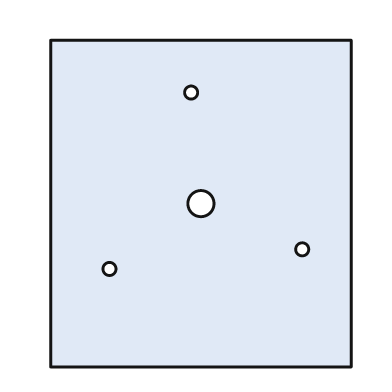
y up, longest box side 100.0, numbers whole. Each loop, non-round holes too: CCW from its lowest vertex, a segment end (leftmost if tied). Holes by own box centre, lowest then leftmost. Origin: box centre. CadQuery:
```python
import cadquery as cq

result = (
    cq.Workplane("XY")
    .moveTo(-46.0, -50.0)
    .lineTo(46.0, -50.0)
    .lineTo(46.0, 50.0)
    .lineTo(-46.0, 50.0)
    .close()
    .moveTo(-28.0, -20.0)
    .circle(2.0)
    .moveTo(31.0, -14.0)
    .circle(2.0)
    .moveTo(0.0, 0.0)
    .circle(4.0)
    .moveTo(-3.0, 34.0)
    .circle(2.0)
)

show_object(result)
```